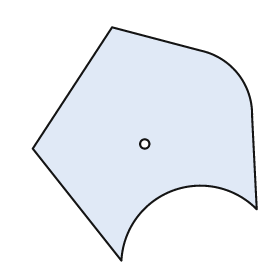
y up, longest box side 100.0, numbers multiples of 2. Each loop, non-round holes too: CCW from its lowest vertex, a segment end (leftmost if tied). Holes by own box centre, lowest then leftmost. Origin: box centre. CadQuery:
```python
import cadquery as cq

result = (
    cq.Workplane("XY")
    .moveTo(-10.0, -50.0)
    .threePointArc((12.0, -20.0), (48.0, -28.0))
    .lineTo(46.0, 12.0)
    .threePointArc((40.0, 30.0), (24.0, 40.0))
    .lineTo(-14.0, 50.0)
    .lineTo(-48.0, -2.0)
    .close()
    .moveTo(0.0, 0.0)
    .circle(2.0)
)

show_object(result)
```